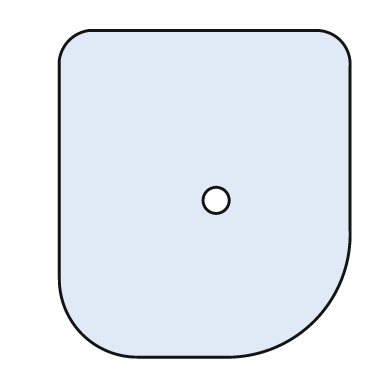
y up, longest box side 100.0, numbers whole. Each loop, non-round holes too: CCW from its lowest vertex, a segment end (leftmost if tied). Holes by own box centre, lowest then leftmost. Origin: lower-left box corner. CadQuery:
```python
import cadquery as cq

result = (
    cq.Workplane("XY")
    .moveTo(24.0, 0.0)
    .lineTo(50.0, 0.0)
    .threePointArc((78.0, 11.0), (89.0, 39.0))
    .lineTo(89.0, 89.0)
    .threePointArc((86.0, 97.0), (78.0, 100.0))
    .lineTo(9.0, 100.0)
    .threePointArc((3.0, 97.0), (0.0, 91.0))
    .lineTo(0.0, 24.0)
    .threePointArc((7.0, 7.0), (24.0, 0.0))
    .close()
    .moveTo(48.0, 48.0)
    .circle(4.0)
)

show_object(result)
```